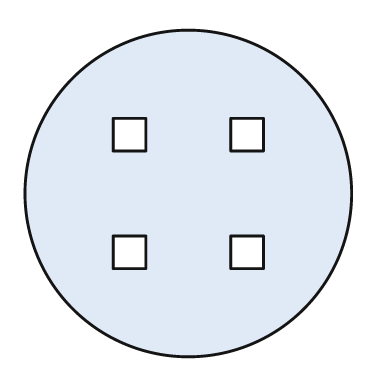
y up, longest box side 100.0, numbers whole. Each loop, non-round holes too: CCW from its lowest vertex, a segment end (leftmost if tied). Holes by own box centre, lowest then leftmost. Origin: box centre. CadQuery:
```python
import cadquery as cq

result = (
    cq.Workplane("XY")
    .moveTo(0.0, 0.0)
    .circle(50.0)
    .moveTo(-23.0, -23.0)
    .lineTo(-13.0, -23.0)
    .lineTo(-13.0, -13.0)
    .lineTo(-23.0, -13.0)
    .close()
    .moveTo(13.0, -23.0)
    .lineTo(23.0, -23.0)
    .lineTo(23.0, -13.0)
    .lineTo(13.0, -13.0)
    .close()
    .moveTo(-23.0, 13.0)
    .lineTo(-13.0, 13.0)
    .lineTo(-13.0, 23.0)
    .lineTo(-23.0, 23.0)
    .close()
    .moveTo(13.0, 13.0)
    .lineTo(23.0, 13.0)
    .lineTo(23.0, 23.0)
    .lineTo(13.0, 23.0)
    .close()
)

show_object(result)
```